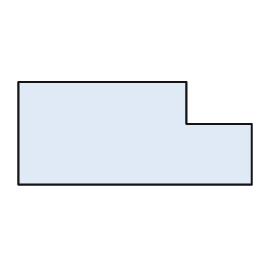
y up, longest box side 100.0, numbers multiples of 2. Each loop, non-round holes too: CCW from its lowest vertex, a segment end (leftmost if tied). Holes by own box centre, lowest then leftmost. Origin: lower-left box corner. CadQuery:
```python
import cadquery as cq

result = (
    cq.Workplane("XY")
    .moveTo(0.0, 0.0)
    .lineTo(100.0, 0.0)
    .lineTo(100.0, 26.0)
    .lineTo(72.0, 26.0)
    .lineTo(72.0, 44.0)
    .lineTo(0.0, 44.0)
    .close()
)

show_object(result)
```